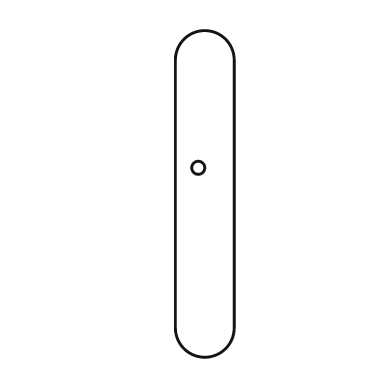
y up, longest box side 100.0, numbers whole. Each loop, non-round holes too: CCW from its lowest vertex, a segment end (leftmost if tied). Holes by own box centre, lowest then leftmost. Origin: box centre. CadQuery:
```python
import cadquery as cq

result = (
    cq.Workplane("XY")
    .moveTo(-9.0, -41.0)
    .threePointArc((0.0, -50.0), (9.0, -41.0))
    .lineTo(9.0, 41.0)
    .threePointArc((0.0, 50.0), (-9.0, 41.0))
    .close()
    .moveTo(-2.0, 8.0)
    .circle(2.0)
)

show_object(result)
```